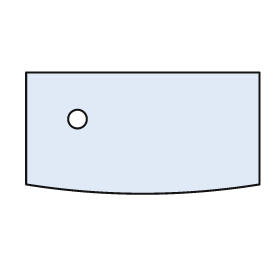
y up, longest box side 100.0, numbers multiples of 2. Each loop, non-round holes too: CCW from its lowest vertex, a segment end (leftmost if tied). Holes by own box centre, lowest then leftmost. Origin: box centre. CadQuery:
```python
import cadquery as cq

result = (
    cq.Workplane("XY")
    .moveTo(-50.0, -22.0)
    .threePointArc((0.0, -26.0), (50.0, -22.0))
    .lineTo(50.0, 26.0)
    .lineTo(-50.0, 26.0)
    .close()
    .moveTo(-28.0, 6.0)
    .circle(4.0)
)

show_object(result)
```